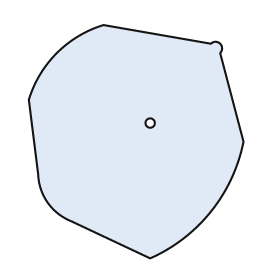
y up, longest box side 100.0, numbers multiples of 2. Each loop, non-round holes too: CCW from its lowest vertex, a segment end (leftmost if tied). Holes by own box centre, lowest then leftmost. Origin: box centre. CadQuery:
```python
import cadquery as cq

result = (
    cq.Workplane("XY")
    .moveTo(6.0, -50.0)
    .threePointArc((32.0, -30.0), (46.0, 0.0))
    .lineTo(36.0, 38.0)
    .threePointArc((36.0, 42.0), (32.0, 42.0))
    .lineTo(-14.0, 50.0)
    .threePointArc((-34.0, 38.0), (-46.0, 18.0))
    .lineTo(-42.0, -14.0)
    .threePointArc((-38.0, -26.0), (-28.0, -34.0))
    .close()
    .moveTo(6.0, 8.0)
    .circle(2.0)
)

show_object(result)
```